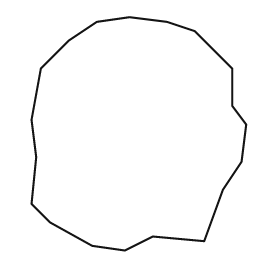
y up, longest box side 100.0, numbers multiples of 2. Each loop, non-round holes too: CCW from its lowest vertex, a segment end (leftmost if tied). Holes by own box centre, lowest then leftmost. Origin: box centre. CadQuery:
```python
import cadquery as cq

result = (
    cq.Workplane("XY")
    .moveTo(-6.0, -50.0)
    .lineTo(6.0, -44.0)
    .lineTo(28.0, -46.0)
    .lineTo(36.0, -24.0)
    .lineTo(44.0, -12.0)
    .lineTo(46.0, 4.0)
    .lineTo(40.0, 12.0)
    .lineTo(40.0, 28.0)
    .lineTo(24.0, 44.0)
    .lineTo(12.0, 48.0)
    .lineTo(-4.0, 50.0)
    .lineTo(-18.0, 48.0)
    .lineTo(-30.0, 40.0)
    .lineTo(-42.0, 28.0)
    .lineTo(-46.0, 6.0)
    .lineTo(-44.0, -10.0)
    .lineTo(-46.0, -30.0)
    .lineTo(-38.0, -38.0)
    .lineTo(-20.0, -48.0)
    .close()
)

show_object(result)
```